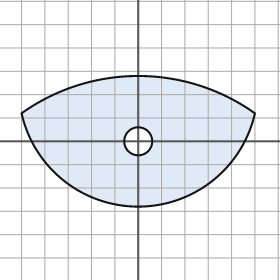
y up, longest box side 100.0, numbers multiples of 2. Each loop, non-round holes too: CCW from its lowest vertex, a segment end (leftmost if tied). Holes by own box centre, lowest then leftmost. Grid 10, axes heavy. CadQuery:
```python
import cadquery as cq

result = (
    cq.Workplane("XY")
    .moveTo(-50.0, 12.0)
    .threePointArc((0.0, -28.0), (50.0, 12.0))
    .threePointArc((0.0, 28.0), (-50.0, 12.0))
    .close()
    .moveTo(0.0, 0.0)
    .circle(6.0)
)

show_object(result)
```